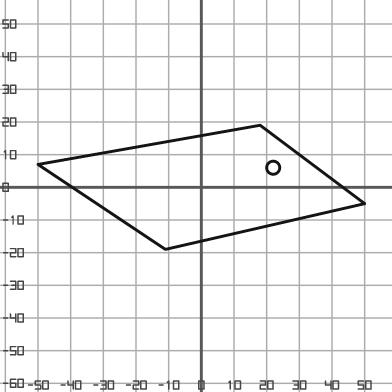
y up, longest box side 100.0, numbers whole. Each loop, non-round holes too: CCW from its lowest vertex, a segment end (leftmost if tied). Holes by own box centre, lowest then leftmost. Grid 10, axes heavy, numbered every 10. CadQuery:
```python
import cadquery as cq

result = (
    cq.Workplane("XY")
    .moveTo(-11.0, -19.0)
    .lineTo(50.0, -5.0)
    .lineTo(18.0, 19.0)
    .lineTo(-50.0, 7.0)
    .close()
    .moveTo(22.0, 6.0)
    .circle(2.0)
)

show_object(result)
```